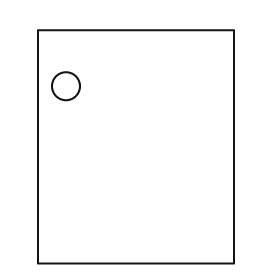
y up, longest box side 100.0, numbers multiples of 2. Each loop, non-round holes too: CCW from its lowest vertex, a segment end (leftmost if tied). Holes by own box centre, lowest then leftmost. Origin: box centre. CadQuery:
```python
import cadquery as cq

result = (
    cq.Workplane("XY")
    .moveTo(-42.0, -50.0)
    .lineTo(42.0, -50.0)
    .lineTo(42.0, 50.0)
    .lineTo(-42.0, 50.0)
    .close()
    .moveTo(-30.0, 26.0)
    .circle(6.0)
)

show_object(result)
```